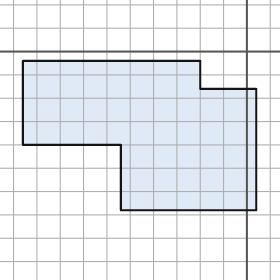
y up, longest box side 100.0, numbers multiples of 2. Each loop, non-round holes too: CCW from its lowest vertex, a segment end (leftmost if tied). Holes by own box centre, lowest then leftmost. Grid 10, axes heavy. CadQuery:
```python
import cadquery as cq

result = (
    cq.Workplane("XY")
    .moveTo(-54.0, -68.0)
    .lineTo(4.0, -68.0)
    .lineTo(4.0, -16.0)
    .lineTo(-20.0, -16.0)
    .lineTo(-20.0, -4.0)
    .lineTo(-96.0, -4.0)
    .lineTo(-96.0, -40.0)
    .lineTo(-54.0, -40.0)
    .close()
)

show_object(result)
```